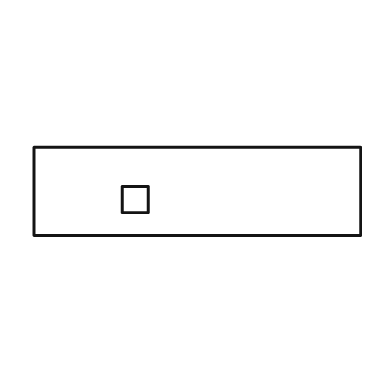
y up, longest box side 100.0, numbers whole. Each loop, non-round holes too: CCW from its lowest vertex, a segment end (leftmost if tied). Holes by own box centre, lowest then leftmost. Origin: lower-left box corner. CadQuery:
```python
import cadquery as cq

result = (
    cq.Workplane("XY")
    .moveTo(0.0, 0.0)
    .lineTo(100.0, 0.0)
    .lineTo(100.0, 27.0)
    .lineTo(0.0, 27.0)
    .close()
    .moveTo(27.0, 7.0)
    .lineTo(35.0, 7.0)
    .lineTo(35.0, 15.0)
    .lineTo(27.0, 15.0)
    .close()
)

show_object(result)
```